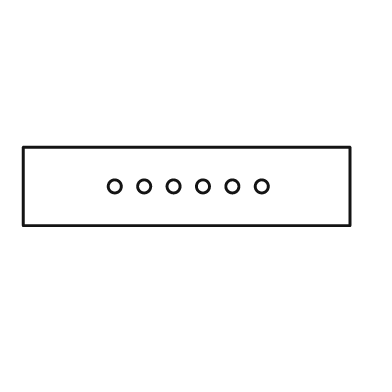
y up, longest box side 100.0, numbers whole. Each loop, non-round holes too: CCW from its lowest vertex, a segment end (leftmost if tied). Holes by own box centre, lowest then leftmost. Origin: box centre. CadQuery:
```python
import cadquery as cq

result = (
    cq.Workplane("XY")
    .moveTo(-50.0, -12.0)
    .lineTo(50.0, -12.0)
    .lineTo(50.0, 12.0)
    .lineTo(-50.0, 12.0)
    .close()
    .moveTo(-22.0, 0.0)
    .circle(2.0)
    .moveTo(-13.0, 0.0)
    .circle(2.0)
    .moveTo(-4.0, 0.0)
    .circle(2.0)
    .moveTo(5.0, 0.0)
    .circle(2.0)
    .moveTo(14.0, 0.0)
    .circle(2.0)
    .moveTo(23.0, 0.0)
    .circle(2.0)
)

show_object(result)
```